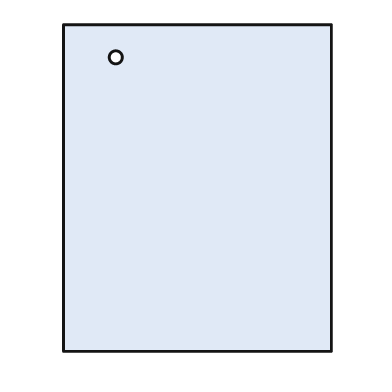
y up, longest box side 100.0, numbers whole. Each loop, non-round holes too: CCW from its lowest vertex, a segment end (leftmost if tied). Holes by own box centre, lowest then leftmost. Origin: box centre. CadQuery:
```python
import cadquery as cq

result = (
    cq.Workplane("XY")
    .moveTo(-41.0, -50.0)
    .lineTo(41.0, -50.0)
    .lineTo(41.0, 50.0)
    .lineTo(-41.0, 50.0)
    .close()
    .moveTo(-25.0, 40.0)
    .circle(2.0)
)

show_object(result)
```